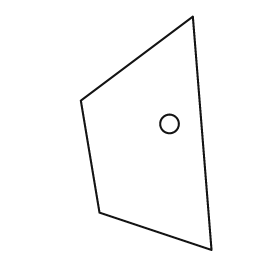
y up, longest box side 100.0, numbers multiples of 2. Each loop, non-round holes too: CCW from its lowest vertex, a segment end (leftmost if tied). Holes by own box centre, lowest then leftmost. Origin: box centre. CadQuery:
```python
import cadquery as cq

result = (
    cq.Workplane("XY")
    .moveTo(28.0, -50.0)
    .lineTo(20.0, 50.0)
    .lineTo(-28.0, 14.0)
    .lineTo(-20.0, -34.0)
    .close()
    .moveTo(10.0, 4.0)
    .circle(4.0)
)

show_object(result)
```